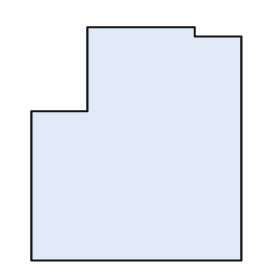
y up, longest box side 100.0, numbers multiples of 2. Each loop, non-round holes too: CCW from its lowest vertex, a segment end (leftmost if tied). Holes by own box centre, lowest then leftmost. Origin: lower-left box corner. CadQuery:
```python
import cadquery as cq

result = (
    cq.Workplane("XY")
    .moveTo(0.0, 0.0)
    .lineTo(90.0, 0.0)
    .lineTo(90.0, 96.0)
    .lineTo(70.0, 96.0)
    .lineTo(70.0, 100.0)
    .lineTo(24.0, 100.0)
    .lineTo(24.0, 64.0)
    .lineTo(0.0, 64.0)
    .close()
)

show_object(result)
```